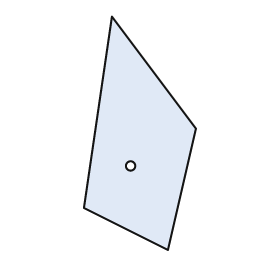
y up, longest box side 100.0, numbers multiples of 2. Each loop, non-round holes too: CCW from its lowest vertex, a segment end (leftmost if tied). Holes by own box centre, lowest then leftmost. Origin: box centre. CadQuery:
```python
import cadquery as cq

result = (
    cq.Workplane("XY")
    .moveTo(12.0, -50.0)
    .lineTo(24.0, 2.0)
    .lineTo(-12.0, 50.0)
    .lineTo(-24.0, -32.0)
    .close()
    .moveTo(-4.0, -14.0)
    .circle(2.0)
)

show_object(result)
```